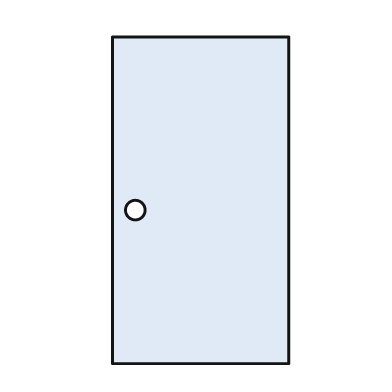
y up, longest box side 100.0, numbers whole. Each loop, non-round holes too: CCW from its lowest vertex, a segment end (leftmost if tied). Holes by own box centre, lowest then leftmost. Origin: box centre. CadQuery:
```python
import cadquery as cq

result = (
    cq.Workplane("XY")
    .moveTo(-27.0, -50.0)
    .lineTo(27.0, -50.0)
    .lineTo(27.0, 50.0)
    .lineTo(-27.0, 50.0)
    .close()
    .moveTo(-20.0, -3.0)
    .circle(3.0)
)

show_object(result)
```